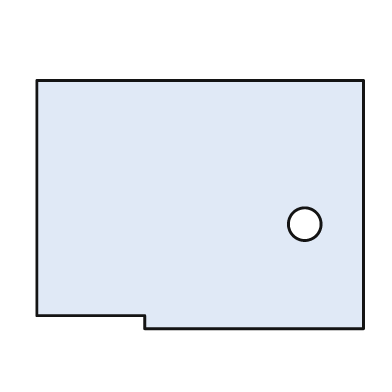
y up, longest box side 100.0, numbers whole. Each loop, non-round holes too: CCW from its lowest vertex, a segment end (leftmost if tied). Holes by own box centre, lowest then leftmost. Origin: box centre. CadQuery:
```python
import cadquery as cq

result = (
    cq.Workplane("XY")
    .moveTo(-17.0, -38.0)
    .lineTo(50.0, -38.0)
    .lineTo(50.0, 38.0)
    .lineTo(-50.0, 38.0)
    .lineTo(-50.0, -34.0)
    .lineTo(-17.0, -34.0)
    .close()
    .moveTo(32.0, -6.0)
    .circle(5.0)
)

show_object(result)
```